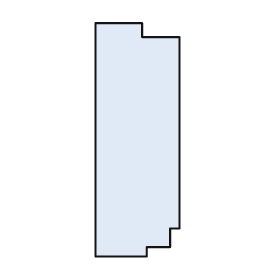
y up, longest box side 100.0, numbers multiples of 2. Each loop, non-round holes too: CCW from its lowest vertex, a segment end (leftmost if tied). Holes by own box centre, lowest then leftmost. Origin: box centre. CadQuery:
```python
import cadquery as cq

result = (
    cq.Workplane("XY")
    .moveTo(-18.0, -50.0)
    .lineTo(4.0, -50.0)
    .lineTo(4.0, -46.0)
    .lineTo(14.0, -46.0)
    .lineTo(14.0, -38.0)
    .lineTo(18.0, -38.0)
    .lineTo(18.0, 44.0)
    .lineTo(2.0, 44.0)
    .lineTo(2.0, 50.0)
    .lineTo(-18.0, 50.0)
    .close()
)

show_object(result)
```